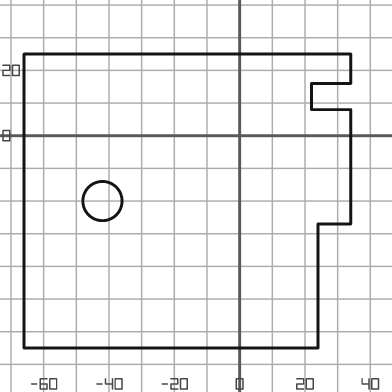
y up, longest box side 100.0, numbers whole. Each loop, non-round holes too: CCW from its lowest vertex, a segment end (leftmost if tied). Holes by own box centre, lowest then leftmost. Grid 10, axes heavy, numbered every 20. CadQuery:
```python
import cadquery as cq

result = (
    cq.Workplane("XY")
    .moveTo(-66.0, -65.0)
    .lineTo(24.0, -65.0)
    .lineTo(24.0, -27.0)
    .lineTo(34.0, -27.0)
    .lineTo(34.0, 8.0)
    .lineTo(22.0, 8.0)
    .lineTo(22.0, 16.0)
    .lineTo(34.0, 16.0)
    .lineTo(34.0, 25.0)
    .lineTo(-66.0, 25.0)
    .close()
    .moveTo(-42.0, -20.0)
    .circle(6.0)
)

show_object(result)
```